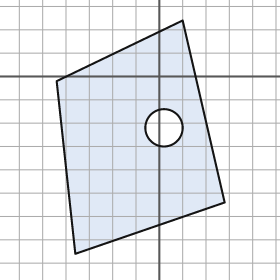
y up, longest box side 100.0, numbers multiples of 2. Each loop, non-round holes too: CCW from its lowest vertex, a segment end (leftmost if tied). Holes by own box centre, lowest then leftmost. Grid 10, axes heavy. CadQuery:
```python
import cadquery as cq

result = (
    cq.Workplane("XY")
    .moveTo(-36.0, -76.0)
    .lineTo(28.0, -54.0)
    .lineTo(10.0, 24.0)
    .lineTo(-44.0, -2.0)
    .close()
    .moveTo(2.0, -22.0)
    .circle(8.0)
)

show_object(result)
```